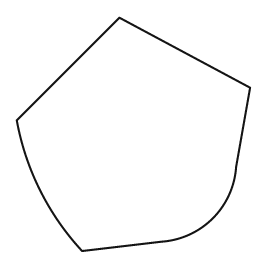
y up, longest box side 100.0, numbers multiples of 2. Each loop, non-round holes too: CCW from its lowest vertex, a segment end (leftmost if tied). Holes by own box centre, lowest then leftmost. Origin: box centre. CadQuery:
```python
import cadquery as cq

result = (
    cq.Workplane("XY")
    .moveTo(-22.0, -50.0)
    .lineTo(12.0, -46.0)
    .threePointArc((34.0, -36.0), (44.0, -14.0))
    .lineTo(50.0, 20.0)
    .lineTo(-6.0, 50.0)
    .lineTo(-50.0, 6.0)
    .threePointArc((-40.0, -24.0), (-22.0, -50.0))
    .close()
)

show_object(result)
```